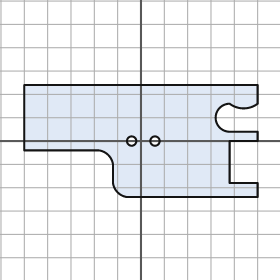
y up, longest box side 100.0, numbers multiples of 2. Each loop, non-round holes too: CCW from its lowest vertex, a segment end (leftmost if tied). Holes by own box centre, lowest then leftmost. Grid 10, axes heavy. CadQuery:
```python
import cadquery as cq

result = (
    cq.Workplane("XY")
    .moveTo(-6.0, -24.0)
    .lineTo(50.0, -24.0)
    .lineTo(50.0, -18.0)
    .lineTo(38.0, -18.0)
    .lineTo(38.0, 0.0)
    .lineTo(50.0, 0.0)
    .lineTo(50.0, 4.0)
    .lineTo(38.0, 4.0)
    .threePointArc((32.0, 10.0), (38.0, 16.0))
    .threePointArc((44.0, 14.0), (50.0, 16.0))
    .lineTo(50.0, 24.0)
    .lineTo(-50.0, 24.0)
    .lineTo(-50.0, -4.0)
    .lineTo(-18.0, -4.0)
    .threePointArc((-14.0, -6.0), (-12.0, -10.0))
    .lineTo(-12.0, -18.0)
    .threePointArc((-10.0, -22.0), (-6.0, -24.0))
    .close()
    .moveTo(-4.0, 0.0)
    .circle(2.0)
    .moveTo(6.0, 0.0)
    .circle(2.0)
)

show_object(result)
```